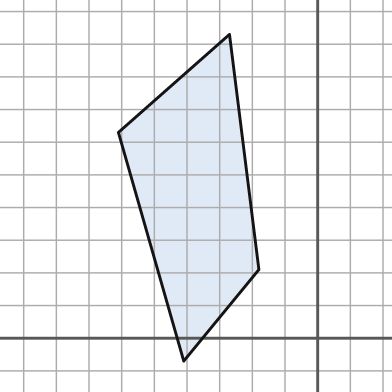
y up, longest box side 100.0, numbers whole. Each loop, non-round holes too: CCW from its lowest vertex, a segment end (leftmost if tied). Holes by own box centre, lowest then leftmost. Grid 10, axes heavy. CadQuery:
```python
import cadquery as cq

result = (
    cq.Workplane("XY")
    .moveTo(-41.0, -7.0)
    .lineTo(-18.0, 21.0)
    .lineTo(-27.0, 93.0)
    .lineTo(-61.0, 63.0)
    .close()
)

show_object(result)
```